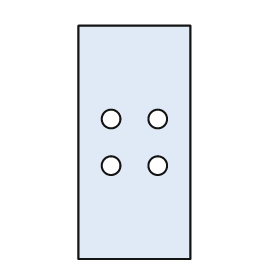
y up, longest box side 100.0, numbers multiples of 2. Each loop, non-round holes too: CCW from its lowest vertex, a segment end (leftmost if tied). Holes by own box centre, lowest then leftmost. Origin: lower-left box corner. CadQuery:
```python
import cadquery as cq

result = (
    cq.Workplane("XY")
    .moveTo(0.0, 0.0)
    .lineTo(48.0, 0.0)
    .lineTo(48.0, 100.0)
    .lineTo(0.0, 100.0)
    .close()
    .moveTo(14.0, 40.0)
    .circle(4.0)
    .moveTo(34.0, 40.0)
    .circle(4.0)
    .moveTo(14.0, 60.0)
    .circle(4.0)
    .moveTo(34.0, 60.0)
    .circle(4.0)
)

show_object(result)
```